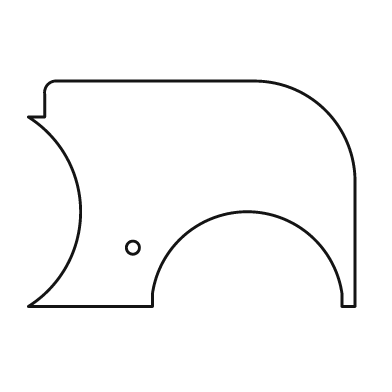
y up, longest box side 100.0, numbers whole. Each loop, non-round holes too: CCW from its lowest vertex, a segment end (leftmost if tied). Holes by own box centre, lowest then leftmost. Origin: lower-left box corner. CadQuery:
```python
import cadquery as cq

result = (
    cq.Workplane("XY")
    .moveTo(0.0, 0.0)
    .lineTo(38.0, 0.0)
    .lineTo(38.0, 4.0)
    .threePointArc((67.0, 29.0), (96.0, 4.0))
    .lineTo(96.0, 0.0)
    .lineTo(100.0, 0.0)
    .lineTo(100.0, 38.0)
    .threePointArc((91.0, 60.0), (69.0, 69.0))
    .lineTo(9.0, 69.0)
    .threePointArc((6.0, 68.0), (5.0, 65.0))
    .lineTo(5.0, 58.0)
    .lineTo(0.0, 58.0)
    .threePointArc((16.0, 29.0), (0.0, 0.0))
    .close()
    .moveTo(32.0, 18.0)
    .circle(2.0)
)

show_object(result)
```